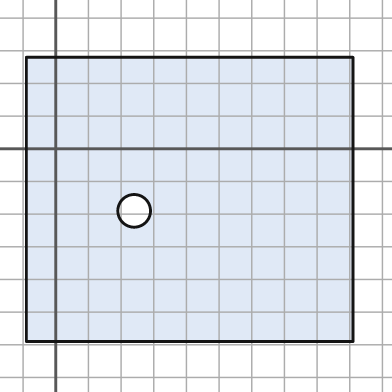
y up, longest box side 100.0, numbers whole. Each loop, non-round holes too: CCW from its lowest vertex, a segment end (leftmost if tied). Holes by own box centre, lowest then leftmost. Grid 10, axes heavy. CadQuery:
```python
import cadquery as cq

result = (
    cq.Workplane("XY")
    .moveTo(-9.0, -59.0)
    .lineTo(91.0, -59.0)
    .lineTo(91.0, 28.0)
    .lineTo(-9.0, 28.0)
    .close()
    .moveTo(24.0, -19.0)
    .circle(5.0)
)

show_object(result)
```